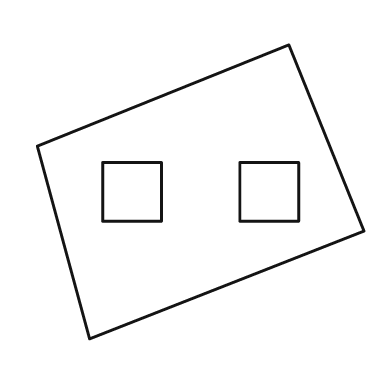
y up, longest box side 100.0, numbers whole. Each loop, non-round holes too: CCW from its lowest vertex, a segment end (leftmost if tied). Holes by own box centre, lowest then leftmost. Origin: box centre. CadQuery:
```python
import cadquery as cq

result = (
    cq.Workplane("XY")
    .moveTo(-34.0, -45.0)
    .lineTo(50.0, -12.0)
    .lineTo(27.0, 45.0)
    .lineTo(-50.0, 14.0)
    .close()
    .moveTo(-30.0, -9.0)
    .lineTo(-12.0, -9.0)
    .lineTo(-12.0, 9.0)
    .lineTo(-30.0, 9.0)
    .close()
    .moveTo(12.0, -9.0)
    .lineTo(30.0, -9.0)
    .lineTo(30.0, 9.0)
    .lineTo(12.0, 9.0)
    .close()
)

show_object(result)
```